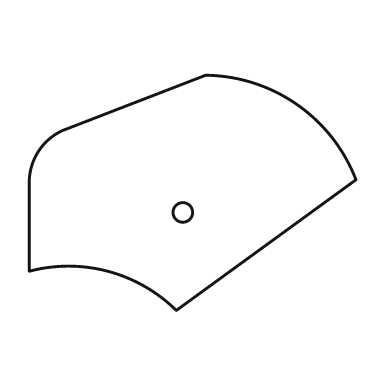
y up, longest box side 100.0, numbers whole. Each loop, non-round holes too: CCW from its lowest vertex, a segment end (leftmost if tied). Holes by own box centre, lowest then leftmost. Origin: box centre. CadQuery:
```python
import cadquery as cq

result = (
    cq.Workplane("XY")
    .moveTo(-5.0, -36.0)
    .lineTo(50.0, 4.0)
    .threePointArc((32.0, 27.0), (4.0, 36.0))
    .lineTo(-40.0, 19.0)
    .threePointArc((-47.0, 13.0), (-50.0, 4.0))
    .lineTo(-50.0, -24.0)
    .threePointArc((-26.0, -24.0), (-5.0, -36.0))
    .close()
    .moveTo(-3.0, -6.0)
    .circle(3.0)
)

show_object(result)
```